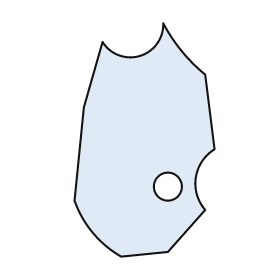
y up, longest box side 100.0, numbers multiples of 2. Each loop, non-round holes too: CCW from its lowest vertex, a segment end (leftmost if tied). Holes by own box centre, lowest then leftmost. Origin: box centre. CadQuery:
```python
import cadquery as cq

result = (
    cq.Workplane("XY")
    .moveTo(-10.0, -50.0)
    .lineTo(10.0, -48.0)
    .lineTo(26.0, -30.0)
    .threePointArc((22.0, -16.0), (30.0, -4.0))
    .lineTo(26.0, 28.0)
    .threePointArc((16.0, 38.0), (8.0, 50.0))
    .threePointArc((-2.0, 36.0), (-18.0, 42.0))
    .lineTo(-26.0, 14.0)
    .lineTo(-30.0, -26.0)
    .threePointArc((-22.0, -40.0), (-10.0, -50.0))
    .close()
    .moveTo(10.0, -20.0)
    .circle(6.0)
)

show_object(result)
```